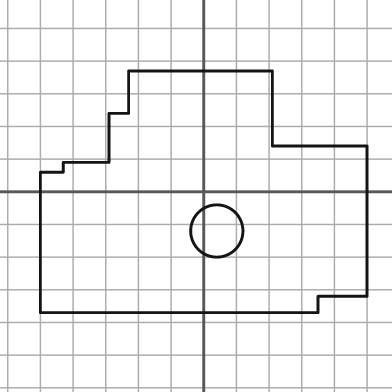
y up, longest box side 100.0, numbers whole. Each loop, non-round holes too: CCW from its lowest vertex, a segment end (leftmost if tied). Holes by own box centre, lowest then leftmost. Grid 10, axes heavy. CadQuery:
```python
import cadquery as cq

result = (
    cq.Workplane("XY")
    .moveTo(-50.0, -37.0)
    .lineTo(35.0, -37.0)
    .lineTo(35.0, -32.0)
    .lineTo(50.0, -32.0)
    .lineTo(50.0, 14.0)
    .lineTo(21.0, 14.0)
    .lineTo(21.0, 37.0)
    .lineTo(-23.0, 37.0)
    .lineTo(-23.0, 24.0)
    .lineTo(-29.0, 24.0)
    .lineTo(-29.0, 9.0)
    .lineTo(-43.0, 9.0)
    .lineTo(-43.0, 6.0)
    .lineTo(-50.0, 6.0)
    .close()
    .moveTo(4.0, -12.0)
    .circle(8.0)
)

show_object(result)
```